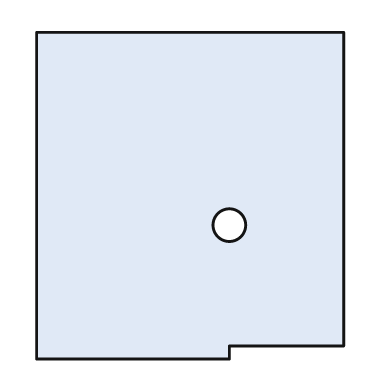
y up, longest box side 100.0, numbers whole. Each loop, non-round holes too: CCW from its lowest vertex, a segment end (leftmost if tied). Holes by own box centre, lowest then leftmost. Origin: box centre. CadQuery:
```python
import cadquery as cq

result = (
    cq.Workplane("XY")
    .moveTo(-47.0, -50.0)
    .lineTo(12.0, -50.0)
    .lineTo(12.0, -46.0)
    .lineTo(47.0, -46.0)
    .lineTo(47.0, 50.0)
    .lineTo(-47.0, 50.0)
    .close()
    .moveTo(12.0, -9.0)
    .circle(5.0)
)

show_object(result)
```